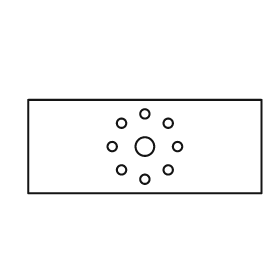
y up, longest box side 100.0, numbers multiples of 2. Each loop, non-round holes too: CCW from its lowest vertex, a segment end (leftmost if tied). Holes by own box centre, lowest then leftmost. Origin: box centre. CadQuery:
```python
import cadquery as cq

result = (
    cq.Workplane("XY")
    .moveTo(-50.0, -20.0)
    .lineTo(50.0, -20.0)
    .lineTo(50.0, 20.0)
    .lineTo(-50.0, 20.0)
    .close()
    .moveTo(0.0, -14.0)
    .circle(2.0)
    .moveTo(-10.0, -10.0)
    .circle(2.0)
    .moveTo(10.0, -10.0)
    .circle(2.0)
    .moveTo(-14.0, 0.0)
    .circle(2.0)
    .moveTo(0.0, 0.0)
    .circle(4.0)
    .moveTo(14.0, 0.0)
    .circle(2.0)
    .moveTo(-10.0, 10.0)
    .circle(2.0)
    .moveTo(10.0, 10.0)
    .circle(2.0)
    .moveTo(0.0, 14.0)
    .circle(2.0)
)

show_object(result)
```